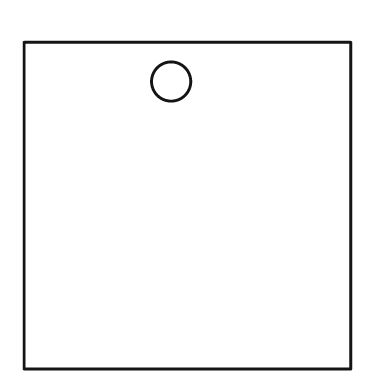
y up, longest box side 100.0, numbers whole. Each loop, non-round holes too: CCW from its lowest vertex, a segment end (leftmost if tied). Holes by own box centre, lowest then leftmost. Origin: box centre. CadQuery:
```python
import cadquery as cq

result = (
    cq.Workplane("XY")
    .moveTo(-50.0, -50.0)
    .lineTo(50.0, -50.0)
    .lineTo(50.0, 50.0)
    .lineTo(-50.0, 50.0)
    .close()
    .moveTo(-5.0, 38.0)
    .circle(6.0)
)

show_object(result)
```